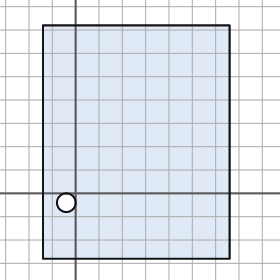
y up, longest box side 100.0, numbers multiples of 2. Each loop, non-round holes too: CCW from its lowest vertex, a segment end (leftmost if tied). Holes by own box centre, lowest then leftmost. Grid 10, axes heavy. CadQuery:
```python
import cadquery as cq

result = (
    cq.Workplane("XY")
    .moveTo(-14.0, -28.0)
    .lineTo(66.0, -28.0)
    .lineTo(66.0, 72.0)
    .lineTo(-14.0, 72.0)
    .close()
    .moveTo(-4.0, -4.0)
    .circle(4.0)
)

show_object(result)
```